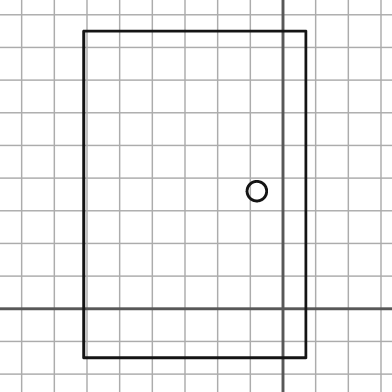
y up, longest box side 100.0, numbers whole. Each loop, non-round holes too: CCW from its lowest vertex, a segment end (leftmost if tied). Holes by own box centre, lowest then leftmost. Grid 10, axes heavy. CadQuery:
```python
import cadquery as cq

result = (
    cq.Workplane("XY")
    .moveTo(-61.0, -15.0)
    .lineTo(7.0, -15.0)
    .lineTo(7.0, 85.0)
    .lineTo(-61.0, 85.0)
    .close()
    .moveTo(-8.0, 36.0)
    .circle(3.0)
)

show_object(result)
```